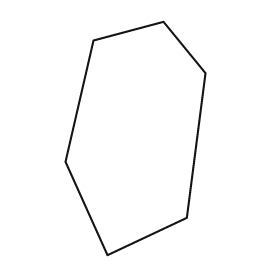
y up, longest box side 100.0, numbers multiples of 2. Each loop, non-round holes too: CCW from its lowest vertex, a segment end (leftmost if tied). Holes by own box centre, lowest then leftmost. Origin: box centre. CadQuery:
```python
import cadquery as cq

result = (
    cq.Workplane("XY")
    .moveTo(-12.0, -50.0)
    .lineTo(22.0, -34.0)
    .lineTo(30.0, 28.0)
    .lineTo(12.0, 50.0)
    .lineTo(-18.0, 42.0)
    .lineTo(-30.0, -10.0)
    .close()
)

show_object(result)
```